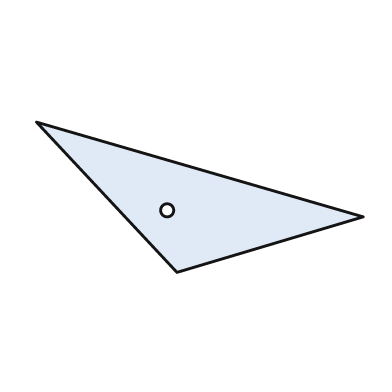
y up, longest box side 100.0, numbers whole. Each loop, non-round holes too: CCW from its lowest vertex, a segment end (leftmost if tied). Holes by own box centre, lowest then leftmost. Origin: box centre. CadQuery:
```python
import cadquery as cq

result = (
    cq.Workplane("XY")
    .moveTo(-7.0, -23.0)
    .lineTo(50.0, -6.0)
    .lineTo(-50.0, 23.0)
    .close()
    .moveTo(-10.0, -4.0)
    .circle(2.0)
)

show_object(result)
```